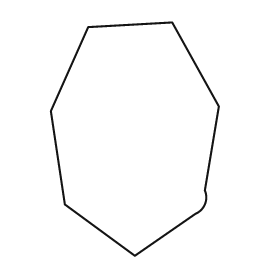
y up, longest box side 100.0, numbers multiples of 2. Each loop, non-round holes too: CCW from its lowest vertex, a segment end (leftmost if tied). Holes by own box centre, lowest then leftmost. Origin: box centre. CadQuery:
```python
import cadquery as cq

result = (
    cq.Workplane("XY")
    .moveTo(0.0, -50.0)
    .lineTo(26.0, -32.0)
    .threePointArc((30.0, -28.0), (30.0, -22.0))
    .lineTo(36.0, 14.0)
    .lineTo(16.0, 50.0)
    .lineTo(-20.0, 48.0)
    .lineTo(-36.0, 12.0)
    .lineTo(-30.0, -28.0)
    .close()
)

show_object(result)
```